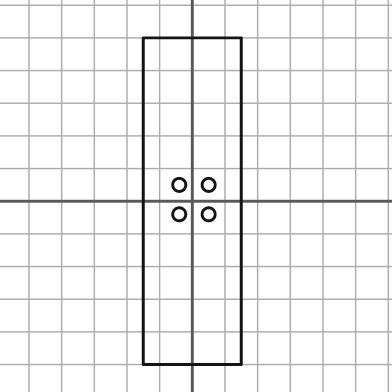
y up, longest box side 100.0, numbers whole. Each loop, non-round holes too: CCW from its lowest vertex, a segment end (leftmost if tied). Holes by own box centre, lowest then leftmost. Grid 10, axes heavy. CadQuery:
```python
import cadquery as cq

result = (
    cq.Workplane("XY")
    .moveTo(-15.0, -50.0)
    .lineTo(15.0, -50.0)
    .lineTo(15.0, 50.0)
    .lineTo(-15.0, 50.0)
    .close()
    .moveTo(-4.0, -4.0)
    .circle(2.0)
    .moveTo(5.0, -4.0)
    .circle(2.0)
    .moveTo(-4.0, 5.0)
    .circle(2.0)
    .moveTo(5.0, 5.0)
    .circle(2.0)
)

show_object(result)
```